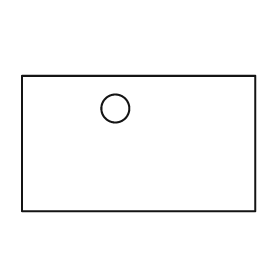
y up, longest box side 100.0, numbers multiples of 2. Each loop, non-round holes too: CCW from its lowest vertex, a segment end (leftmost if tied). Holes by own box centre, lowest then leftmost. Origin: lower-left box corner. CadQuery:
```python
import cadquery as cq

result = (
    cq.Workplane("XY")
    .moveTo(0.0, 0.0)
    .lineTo(100.0, 0.0)
    .lineTo(100.0, 58.0)
    .lineTo(0.0, 58.0)
    .close()
    .moveTo(40.0, 44.0)
    .circle(6.0)
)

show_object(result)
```